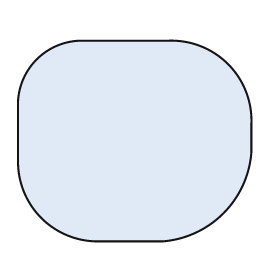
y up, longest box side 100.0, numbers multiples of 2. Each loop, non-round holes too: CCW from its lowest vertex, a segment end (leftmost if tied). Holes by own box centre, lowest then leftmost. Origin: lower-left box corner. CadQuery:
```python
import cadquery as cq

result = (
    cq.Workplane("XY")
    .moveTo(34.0, 0.0)
    .lineTo(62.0, 0.0)
    .threePointArc((88.0, 12.0), (100.0, 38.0))
    .lineTo(100.0, 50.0)
    .threePointArc((90.0, 76.0), (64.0, 86.0))
    .lineTo(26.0, 86.0)
    .threePointArc((8.0, 78.0), (0.0, 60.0))
    .lineTo(0.0, 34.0)
    .threePointArc((10.0, 10.0), (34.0, 0.0))
    .close()
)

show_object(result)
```